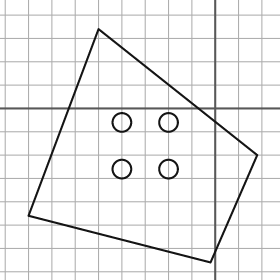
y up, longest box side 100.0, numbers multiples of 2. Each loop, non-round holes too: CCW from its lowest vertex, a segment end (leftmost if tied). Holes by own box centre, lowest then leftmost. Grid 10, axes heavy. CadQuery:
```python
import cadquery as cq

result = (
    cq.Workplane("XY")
    .moveTo(-2.0, -66.0)
    .lineTo(18.0, -20.0)
    .lineTo(-50.0, 34.0)
    .lineTo(-80.0, -46.0)
    .close()
    .moveTo(-40.0, -26.0)
    .circle(4.0)
    .moveTo(-20.0, -26.0)
    .circle(4.0)
    .moveTo(-40.0, -6.0)
    .circle(4.0)
    .moveTo(-20.0, -6.0)
    .circle(4.0)
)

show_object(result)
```